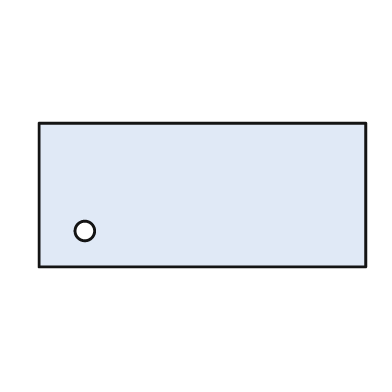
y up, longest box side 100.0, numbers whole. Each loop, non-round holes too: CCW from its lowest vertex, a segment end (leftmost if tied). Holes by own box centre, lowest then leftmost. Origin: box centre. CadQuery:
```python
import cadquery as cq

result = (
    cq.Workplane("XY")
    .moveTo(-50.0, -22.0)
    .lineTo(50.0, -22.0)
    .lineTo(50.0, 22.0)
    .lineTo(-50.0, 22.0)
    .close()
    .moveTo(-36.0, -11.0)
    .circle(3.0)
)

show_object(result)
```